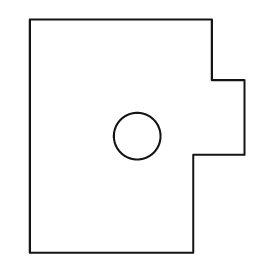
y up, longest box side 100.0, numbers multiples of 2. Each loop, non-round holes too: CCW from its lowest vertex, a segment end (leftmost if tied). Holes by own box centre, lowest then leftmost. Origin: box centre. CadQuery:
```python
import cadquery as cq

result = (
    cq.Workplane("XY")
    .moveTo(-46.0, -50.0)
    .lineTo(24.0, -50.0)
    .lineTo(24.0, -8.0)
    .lineTo(46.0, -8.0)
    .lineTo(46.0, 24.0)
    .lineTo(32.0, 24.0)
    .lineTo(32.0, 50.0)
    .lineTo(-46.0, 50.0)
    .close()
    .moveTo(0.0, 0.0)
    .circle(10.0)
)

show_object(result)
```